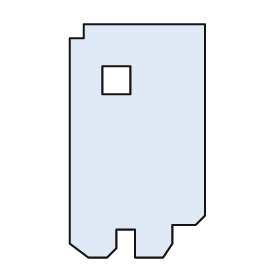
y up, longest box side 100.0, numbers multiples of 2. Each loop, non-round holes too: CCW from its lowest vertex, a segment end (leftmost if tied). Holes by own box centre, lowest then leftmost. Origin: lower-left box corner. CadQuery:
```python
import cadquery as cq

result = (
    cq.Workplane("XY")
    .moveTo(8.0, 0.0)
    .lineTo(16.0, 0.0)
    .lineTo(20.0, 4.0)
    .lineTo(20.0, 12.0)
    .lineTo(28.0, 12.0)
    .lineTo(28.0, 0.0)
    .lineTo(40.0, 0.0)
    .lineTo(44.0, 6.0)
    .lineTo(44.0, 14.0)
    .lineTo(54.0, 14.0)
    .lineTo(58.0, 18.0)
    .lineTo(58.0, 100.0)
    .lineTo(6.0, 100.0)
    .lineTo(6.0, 94.0)
    .lineTo(0.0, 94.0)
    .lineTo(0.0, 6.0)
    .close()
    .moveTo(14.0, 70.0)
    .lineTo(26.0, 70.0)
    .lineTo(26.0, 82.0)
    .lineTo(14.0, 82.0)
    .close()
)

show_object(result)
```